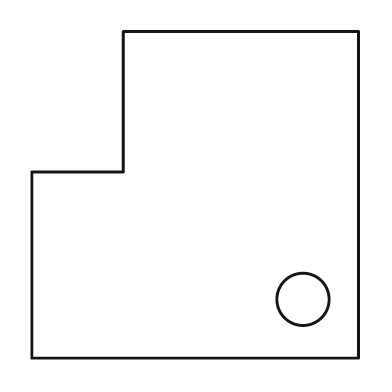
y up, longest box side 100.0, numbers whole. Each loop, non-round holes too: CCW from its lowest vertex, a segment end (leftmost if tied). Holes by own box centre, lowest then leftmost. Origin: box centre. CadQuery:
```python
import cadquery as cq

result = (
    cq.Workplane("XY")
    .moveTo(-50.0, -50.0)
    .lineTo(50.0, -50.0)
    .lineTo(50.0, 50.0)
    .lineTo(-22.0, 50.0)
    .lineTo(-22.0, 7.0)
    .lineTo(-50.0, 7.0)
    .close()
    .moveTo(33.0, -32.0)
    .circle(8.0)
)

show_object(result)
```